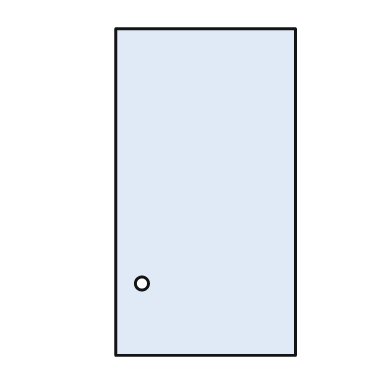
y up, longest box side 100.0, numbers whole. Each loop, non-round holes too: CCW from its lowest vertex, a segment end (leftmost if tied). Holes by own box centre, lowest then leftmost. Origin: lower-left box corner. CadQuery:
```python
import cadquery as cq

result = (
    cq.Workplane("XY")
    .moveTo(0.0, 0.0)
    .lineTo(55.0, 0.0)
    .lineTo(55.0, 100.0)
    .lineTo(0.0, 100.0)
    .close()
    .moveTo(8.0, 22.0)
    .circle(2.0)
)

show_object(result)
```